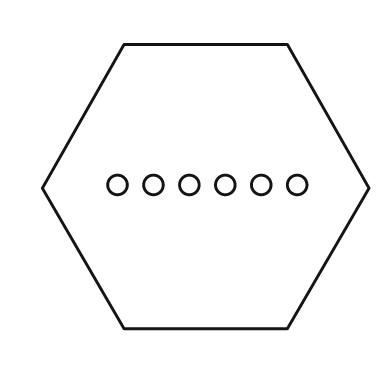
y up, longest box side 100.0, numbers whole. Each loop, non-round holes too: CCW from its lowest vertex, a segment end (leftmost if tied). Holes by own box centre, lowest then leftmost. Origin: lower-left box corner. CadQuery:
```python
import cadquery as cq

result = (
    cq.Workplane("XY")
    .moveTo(25.0, 0.0)
    .lineTo(75.0, 0.0)
    .lineTo(100.0, 43.0)
    .lineTo(75.0, 87.0)
    .lineTo(25.0, 87.0)
    .lineTo(0.0, 43.0)
    .close()
    .moveTo(23.0, 44.0)
    .circle(3.0)
    .moveTo(34.0, 44.0)
    .circle(3.0)
    .moveTo(45.0, 44.0)
    .circle(3.0)
    .moveTo(56.0, 44.0)
    .circle(3.0)
    .moveTo(67.0, 44.0)
    .circle(3.0)
    .moveTo(78.0, 44.0)
    .circle(3.0)
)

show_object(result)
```